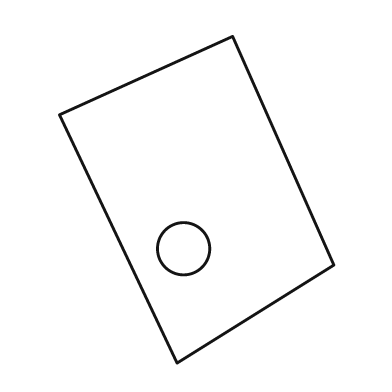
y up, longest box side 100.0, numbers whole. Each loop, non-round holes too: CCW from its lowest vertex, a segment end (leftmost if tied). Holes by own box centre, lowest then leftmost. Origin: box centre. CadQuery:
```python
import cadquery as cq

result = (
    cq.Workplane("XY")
    .moveTo(-6.0, -50.0)
    .lineTo(42.0, -20.0)
    .lineTo(11.0, 50.0)
    .lineTo(-42.0, 26.0)
    .close()
    .moveTo(-4.0, -15.0)
    .circle(8.0)
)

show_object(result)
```